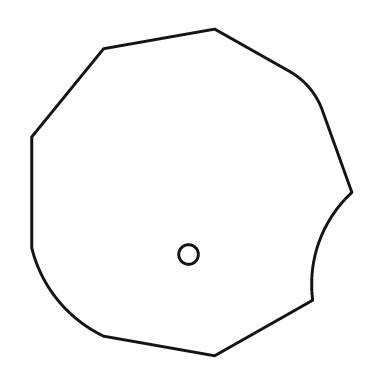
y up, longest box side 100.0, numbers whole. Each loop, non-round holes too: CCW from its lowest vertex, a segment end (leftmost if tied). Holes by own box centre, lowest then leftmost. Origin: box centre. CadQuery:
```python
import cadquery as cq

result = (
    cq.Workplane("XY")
    .moveTo(7.0, -50.0)
    .lineTo(37.0, -33.0)
    .threePointArc((39.0, -15.0), (49.0, 0.0))
    .lineTo(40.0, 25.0)
    .threePointArc((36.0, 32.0), (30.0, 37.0))
    .lineTo(7.0, 50.0)
    .lineTo(-27.0, 44.0)
    .lineTo(-49.0, 17.0)
    .lineTo(-49.0, -17.0)
    .threePointArc((-41.0, -33.0), (-27.0, -44.0))
    .close()
    .moveTo(-1.0, -19.0)
    .circle(3.0)
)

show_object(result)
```